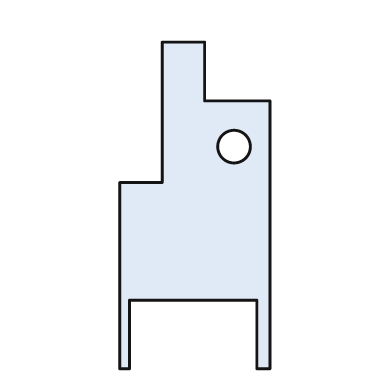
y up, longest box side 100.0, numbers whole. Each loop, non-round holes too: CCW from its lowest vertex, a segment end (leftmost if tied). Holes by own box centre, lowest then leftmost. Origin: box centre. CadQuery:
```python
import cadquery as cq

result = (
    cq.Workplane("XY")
    .moveTo(-23.0, -50.0)
    .lineTo(-20.0, -50.0)
    .lineTo(-20.0, -29.0)
    .lineTo(19.0, -29.0)
    .lineTo(19.0, -50.0)
    .lineTo(23.0, -50.0)
    .lineTo(23.0, 32.0)
    .lineTo(3.0, 32.0)
    .lineTo(3.0, 50.0)
    .lineTo(-10.0, 50.0)
    .lineTo(-10.0, 7.0)
    .lineTo(-23.0, 7.0)
    .close()
    .moveTo(12.0, 18.0)
    .circle(5.0)
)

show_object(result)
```